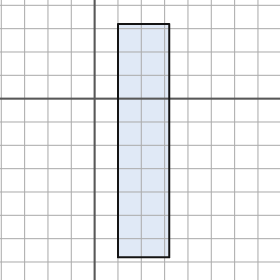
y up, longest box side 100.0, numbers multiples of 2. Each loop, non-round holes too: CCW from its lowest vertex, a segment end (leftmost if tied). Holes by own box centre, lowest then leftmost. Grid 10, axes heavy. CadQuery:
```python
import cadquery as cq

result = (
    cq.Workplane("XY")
    .moveTo(10.0, -68.0)
    .lineTo(32.0, -68.0)
    .lineTo(32.0, 32.0)
    .lineTo(10.0, 32.0)
    .close()
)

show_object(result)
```